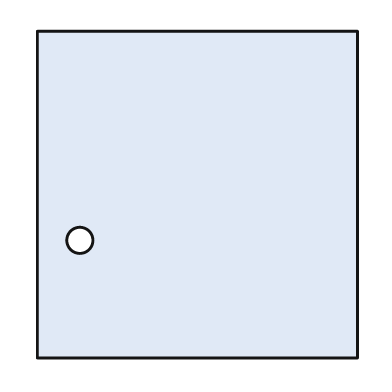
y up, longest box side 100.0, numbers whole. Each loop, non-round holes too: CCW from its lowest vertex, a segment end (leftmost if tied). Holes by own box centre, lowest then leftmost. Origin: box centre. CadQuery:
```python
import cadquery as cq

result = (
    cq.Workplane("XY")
    .moveTo(-49.0, -50.0)
    .lineTo(49.0, -50.0)
    .lineTo(49.0, 50.0)
    .lineTo(-49.0, 50.0)
    .close()
    .moveTo(-36.0, -14.0)
    .circle(4.0)
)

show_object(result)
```